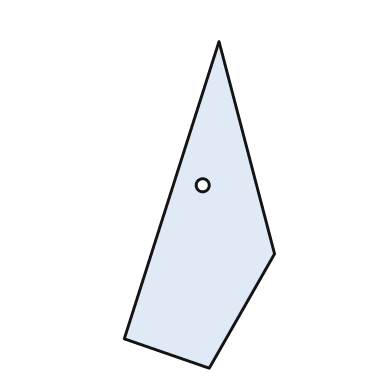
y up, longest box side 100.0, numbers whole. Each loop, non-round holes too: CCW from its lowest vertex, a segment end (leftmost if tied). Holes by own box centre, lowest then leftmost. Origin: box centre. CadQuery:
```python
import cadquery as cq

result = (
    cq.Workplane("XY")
    .moveTo(3.0, -50.0)
    .lineTo(23.0, -15.0)
    .lineTo(6.0, 50.0)
    .lineTo(-23.0, -41.0)
    .close()
    .moveTo(1.0, 6.0)
    .circle(2.0)
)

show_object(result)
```